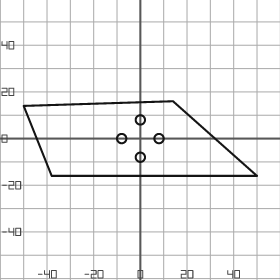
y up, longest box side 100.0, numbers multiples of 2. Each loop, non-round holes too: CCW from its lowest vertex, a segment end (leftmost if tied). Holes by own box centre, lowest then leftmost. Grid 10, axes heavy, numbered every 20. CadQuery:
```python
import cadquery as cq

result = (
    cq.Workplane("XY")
    .moveTo(-38.0, -16.0)
    .lineTo(50.0, -16.0)
    .lineTo(14.0, 16.0)
    .lineTo(-50.0, 14.0)
    .close()
    .moveTo(0.0, -8.0)
    .circle(2.0)
    .moveTo(-8.0, 0.0)
    .circle(2.0)
    .moveTo(8.0, 0.0)
    .circle(2.0)
    .moveTo(0.0, 8.0)
    .circle(2.0)
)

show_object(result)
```